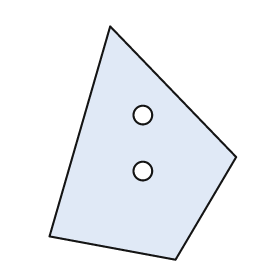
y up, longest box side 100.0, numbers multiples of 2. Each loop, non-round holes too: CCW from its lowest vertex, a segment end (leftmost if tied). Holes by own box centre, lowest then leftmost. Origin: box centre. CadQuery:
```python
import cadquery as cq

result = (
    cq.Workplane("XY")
    .moveTo(14.0, -50.0)
    .lineTo(40.0, -6.0)
    .lineTo(-14.0, 50.0)
    .lineTo(-40.0, -40.0)
    .close()
    .moveTo(0.0, -12.0)
    .circle(4.0)
    .moveTo(0.0, 12.0)
    .circle(4.0)
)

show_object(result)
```